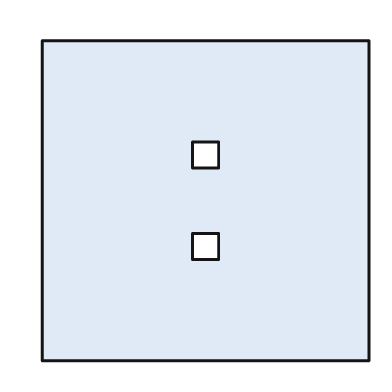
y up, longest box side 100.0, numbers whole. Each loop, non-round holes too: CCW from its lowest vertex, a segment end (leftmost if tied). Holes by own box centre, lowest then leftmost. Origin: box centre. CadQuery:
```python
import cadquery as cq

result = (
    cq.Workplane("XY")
    .moveTo(-50.0, -49.0)
    .lineTo(50.0, -49.0)
    .lineTo(50.0, 49.0)
    .lineTo(-50.0, 49.0)
    .close()
    .moveTo(-4.0, -18.0)
    .lineTo(4.0, -18.0)
    .lineTo(4.0, -10.0)
    .lineTo(-4.0, -10.0)
    .close()
    .moveTo(-4.0, 10.0)
    .lineTo(4.0, 10.0)
    .lineTo(4.0, 18.0)
    .lineTo(-4.0, 18.0)
    .close()
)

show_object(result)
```